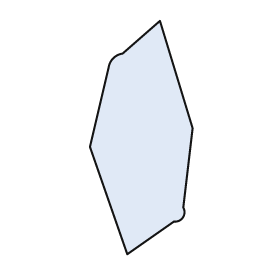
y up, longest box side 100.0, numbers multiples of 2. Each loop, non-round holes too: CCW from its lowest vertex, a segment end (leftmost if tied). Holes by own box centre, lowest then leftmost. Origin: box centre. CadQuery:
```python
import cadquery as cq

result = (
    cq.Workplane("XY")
    .moveTo(-6.0, -50.0)
    .lineTo(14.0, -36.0)
    .threePointArc((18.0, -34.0), (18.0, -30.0))
    .lineTo(22.0, 4.0)
    .lineTo(8.0, 50.0)
    .lineTo(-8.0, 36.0)
    .threePointArc((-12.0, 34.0), (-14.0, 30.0))
    .lineTo(-22.0, -4.0)
    .close()
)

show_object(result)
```